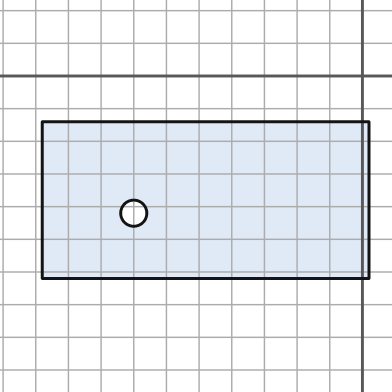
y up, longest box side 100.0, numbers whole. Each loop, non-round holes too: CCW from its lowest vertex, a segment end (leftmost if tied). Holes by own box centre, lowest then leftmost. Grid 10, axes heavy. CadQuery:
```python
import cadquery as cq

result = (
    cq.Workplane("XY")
    .moveTo(-98.0, -62.0)
    .lineTo(2.0, -62.0)
    .lineTo(2.0, -14.0)
    .lineTo(-98.0, -14.0)
    .close()
    .moveTo(-70.0, -42.0)
    .circle(4.0)
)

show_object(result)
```